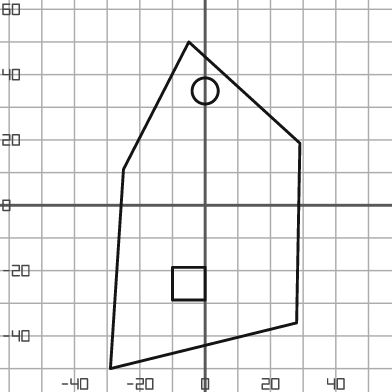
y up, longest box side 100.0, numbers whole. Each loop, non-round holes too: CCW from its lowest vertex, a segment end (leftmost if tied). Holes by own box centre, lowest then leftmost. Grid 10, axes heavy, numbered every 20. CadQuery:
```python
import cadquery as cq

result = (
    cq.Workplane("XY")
    .moveTo(-29.0, -50.0)
    .lineTo(28.0, -36.0)
    .lineTo(29.0, 19.0)
    .lineTo(-5.0, 50.0)
    .lineTo(-25.0, 11.0)
    .close()
    .moveTo(-10.0, -29.0)
    .lineTo(0.0, -29.0)
    .lineTo(0.0, -19.0)
    .lineTo(-10.0, -19.0)
    .close()
    .moveTo(0.0, 35.0)
    .circle(4.0)
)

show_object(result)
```